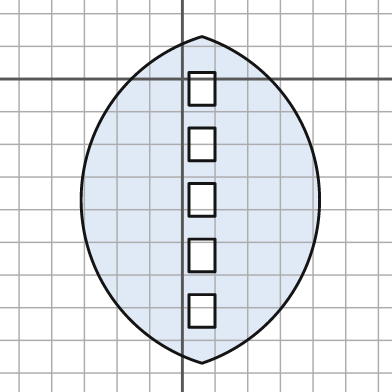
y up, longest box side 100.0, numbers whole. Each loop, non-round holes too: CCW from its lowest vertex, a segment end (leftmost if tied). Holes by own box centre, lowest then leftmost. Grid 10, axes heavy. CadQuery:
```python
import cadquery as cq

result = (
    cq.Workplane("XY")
    .moveTo(6.0, -87.0)
    .threePointArc((42.0, -37.0), (6.0, 13.0))
    .threePointArc((-31.0, -37.0), (6.0, -87.0))
    .close()
    .moveTo(2.0, -76.0)
    .lineTo(10.0, -76.0)
    .lineTo(10.0, -66.0)
    .lineTo(2.0, -66.0)
    .close()
    .moveTo(2.0, -59.0)
    .lineTo(10.0, -59.0)
    .lineTo(10.0, -49.0)
    .lineTo(2.0, -49.0)
    .close()
    .moveTo(2.0, -42.0)
    .lineTo(10.0, -42.0)
    .lineTo(10.0, -32.0)
    .lineTo(2.0, -32.0)
    .close()
    .moveTo(2.0, -25.0)
    .lineTo(10.0, -25.0)
    .lineTo(10.0, -15.0)
    .lineTo(2.0, -15.0)
    .close()
    .moveTo(2.0, -8.0)
    .lineTo(10.0, -8.0)
    .lineTo(10.0, 2.0)
    .lineTo(2.0, 2.0)
    .close()
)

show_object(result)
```